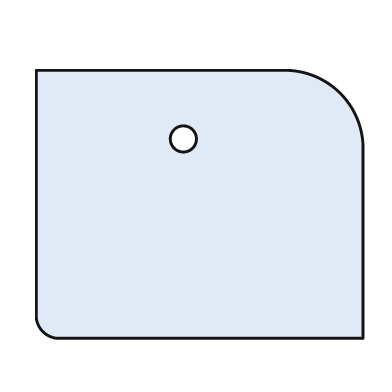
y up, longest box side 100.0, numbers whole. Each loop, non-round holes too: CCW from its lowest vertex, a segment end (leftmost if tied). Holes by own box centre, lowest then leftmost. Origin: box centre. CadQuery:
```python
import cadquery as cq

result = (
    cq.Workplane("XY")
    .moveTo(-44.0, -41.0)
    .lineTo(50.0, -41.0)
    .lineTo(50.0, 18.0)
    .threePointArc((43.0, 34.0), (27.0, 41.0))
    .lineTo(-50.0, 41.0)
    .lineTo(-50.0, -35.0)
    .threePointArc((-48.0, -39.0), (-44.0, -41.0))
    .close()
    .moveTo(-5.0, 20.0)
    .circle(4.0)
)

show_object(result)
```